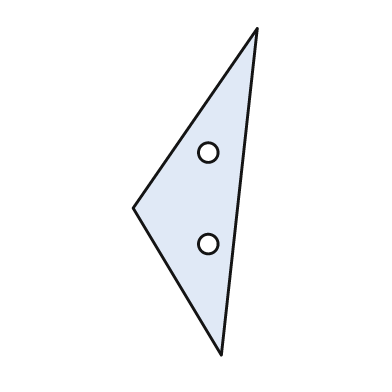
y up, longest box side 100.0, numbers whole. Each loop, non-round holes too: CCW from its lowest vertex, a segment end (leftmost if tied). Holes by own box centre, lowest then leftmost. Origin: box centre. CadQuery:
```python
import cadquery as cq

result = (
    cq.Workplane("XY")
    .moveTo(8.0, -50.0)
    .lineTo(19.0, 50.0)
    .lineTo(-19.0, -5.0)
    .close()
    .moveTo(4.0, -16.0)
    .circle(3.0)
    .moveTo(4.0, 12.0)
    .circle(3.0)
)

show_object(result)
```